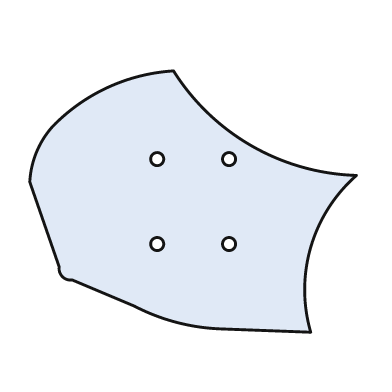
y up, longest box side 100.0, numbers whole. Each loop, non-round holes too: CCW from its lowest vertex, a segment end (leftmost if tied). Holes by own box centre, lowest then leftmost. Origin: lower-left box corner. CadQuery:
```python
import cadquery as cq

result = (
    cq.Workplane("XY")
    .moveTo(86.0, 0.0)
    .threePointArc((86.0, 26.0), (100.0, 48.0))
    .threePointArc((68.0, 57.0), (44.0, 80.0))
    .threePointArc((24.0, 75.0), (7.0, 63.0))
    .threePointArc((2.0, 55.0), (0.0, 46.0))
    .lineTo(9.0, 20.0)
    .threePointArc((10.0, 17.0), (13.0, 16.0))
    .lineTo(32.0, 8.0)
    .threePointArc((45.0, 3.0), (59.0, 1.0))
    .close()
    .moveTo(39.0, 27.0)
    .circle(2.0)
    .moveTo(61.0, 27.0)
    .circle(2.0)
    .moveTo(39.0, 53.0)
    .circle(2.0)
    .moveTo(61.0, 53.0)
    .circle(2.0)
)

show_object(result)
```